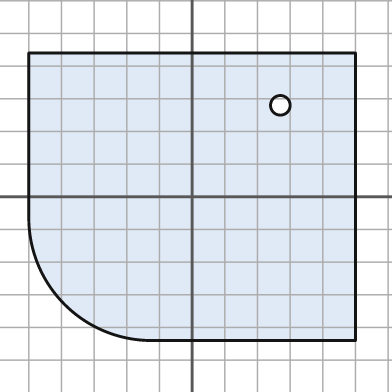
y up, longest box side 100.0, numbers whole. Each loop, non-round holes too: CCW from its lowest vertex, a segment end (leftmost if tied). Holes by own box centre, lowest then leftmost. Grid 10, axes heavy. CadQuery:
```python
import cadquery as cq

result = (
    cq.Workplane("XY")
    .moveTo(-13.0, -44.0)
    .lineTo(50.0, -44.0)
    .lineTo(50.0, 44.0)
    .lineTo(-50.0, 44.0)
    .lineTo(-50.0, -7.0)
    .threePointArc((-39.0, -33.0), (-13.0, -44.0))
    .close()
    .moveTo(27.0, 28.0)
    .circle(3.0)
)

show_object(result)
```